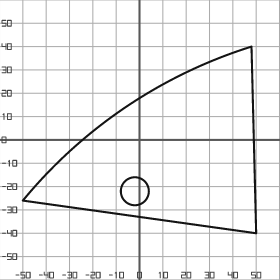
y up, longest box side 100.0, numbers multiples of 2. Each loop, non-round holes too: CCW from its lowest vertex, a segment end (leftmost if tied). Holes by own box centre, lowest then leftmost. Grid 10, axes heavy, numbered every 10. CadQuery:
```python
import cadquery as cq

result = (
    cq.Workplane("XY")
    .moveTo(50.0, -40.0)
    .lineTo(48.0, 40.0)
    .threePointArc((-6.0, 14.0), (-50.0, -26.0))
    .close()
    .moveTo(-2.0, -22.0)
    .circle(6.0)
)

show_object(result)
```